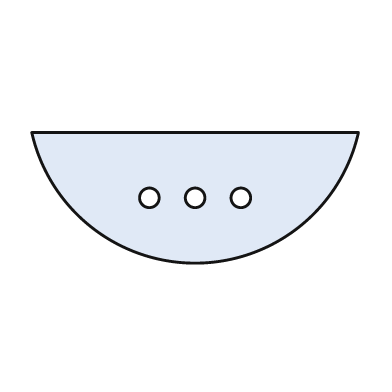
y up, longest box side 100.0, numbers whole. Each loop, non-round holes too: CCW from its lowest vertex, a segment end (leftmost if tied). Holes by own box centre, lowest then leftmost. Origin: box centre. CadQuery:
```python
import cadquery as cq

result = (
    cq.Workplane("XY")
    .moveTo(-50.0, 20.0)
    .threePointArc((0.0, -20.0), (50.0, 20.0))
    .close()
    .moveTo(-14.0, 0.0)
    .circle(3.0)
    .moveTo(0.0, 0.0)
    .circle(3.0)
    .moveTo(14.0, 0.0)
    .circle(3.0)
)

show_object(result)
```